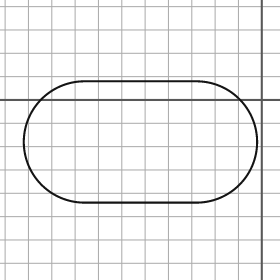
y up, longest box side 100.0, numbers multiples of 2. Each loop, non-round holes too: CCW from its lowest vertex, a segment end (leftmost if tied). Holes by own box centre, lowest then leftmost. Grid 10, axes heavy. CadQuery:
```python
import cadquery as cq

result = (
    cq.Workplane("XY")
    .moveTo(-76.0, -44.0)
    .lineTo(-28.0, -44.0)
    .threePointArc((-2.0, -18.0), (-28.0, 8.0))
    .lineTo(-76.0, 8.0)
    .threePointArc((-102.0, -18.0), (-76.0, -44.0))
    .close()
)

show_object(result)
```